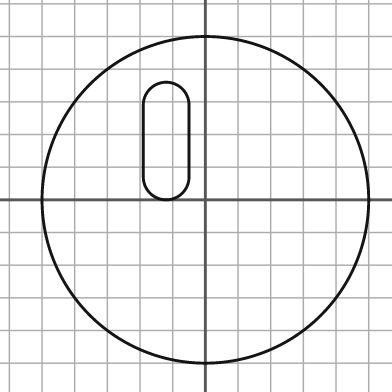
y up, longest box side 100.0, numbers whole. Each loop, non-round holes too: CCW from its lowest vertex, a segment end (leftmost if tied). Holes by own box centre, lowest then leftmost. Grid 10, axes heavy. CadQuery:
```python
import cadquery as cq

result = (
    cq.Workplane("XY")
    .moveTo(0.0, 0.0)
    .circle(50.0)
    .moveTo(-19.0, 7.0)
    .threePointArc((-12.0, 0.0), (-5.0, 7.0))
    .lineTo(-5.0, 29.0)
    .threePointArc((-12.0, 36.0), (-19.0, 29.0))
    .close()
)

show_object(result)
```